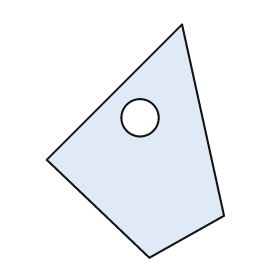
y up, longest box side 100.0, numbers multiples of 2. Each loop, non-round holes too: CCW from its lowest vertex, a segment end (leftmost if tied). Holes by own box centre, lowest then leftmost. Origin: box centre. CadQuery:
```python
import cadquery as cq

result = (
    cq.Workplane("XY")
    .moveTo(6.0, -50.0)
    .lineTo(38.0, -32.0)
    .lineTo(20.0, 50.0)
    .lineTo(-38.0, -8.0)
    .close()
    .moveTo(2.0, 10.0)
    .circle(8.0)
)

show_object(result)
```